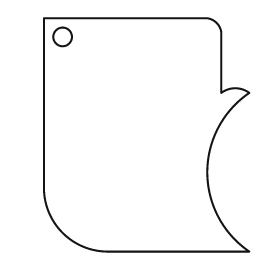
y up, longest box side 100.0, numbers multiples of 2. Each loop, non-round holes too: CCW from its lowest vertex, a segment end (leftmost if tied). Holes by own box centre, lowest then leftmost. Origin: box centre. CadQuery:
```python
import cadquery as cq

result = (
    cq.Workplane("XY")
    .moveTo(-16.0, -50.0)
    .lineTo(44.0, -50.0)
    .threePointArc((26.0, -16.0), (44.0, 18.0))
    .threePointArc((38.0, 20.0), (32.0, 18.0))
    .lineTo(32.0, 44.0)
    .threePointArc((30.0, 48.0), (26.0, 50.0))
    .lineTo(-44.0, 50.0)
    .lineTo(-44.0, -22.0)
    .threePointArc((-36.0, -42.0), (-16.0, -50.0))
    .close()
    .moveTo(-36.0, 42.0)
    .circle(4.0)
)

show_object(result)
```